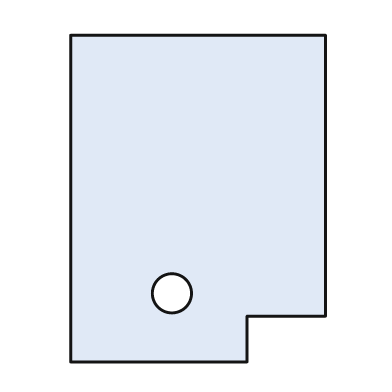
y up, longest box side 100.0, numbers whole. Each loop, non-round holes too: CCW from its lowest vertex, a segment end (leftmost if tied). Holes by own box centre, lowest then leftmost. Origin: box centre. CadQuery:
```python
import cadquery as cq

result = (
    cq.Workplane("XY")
    .moveTo(-39.0, -50.0)
    .lineTo(15.0, -50.0)
    .lineTo(15.0, -36.0)
    .lineTo(39.0, -36.0)
    .lineTo(39.0, 50.0)
    .lineTo(-39.0, 50.0)
    .close()
    .moveTo(-8.0, -29.0)
    .circle(6.0)
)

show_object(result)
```